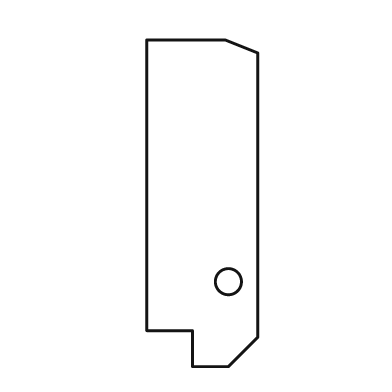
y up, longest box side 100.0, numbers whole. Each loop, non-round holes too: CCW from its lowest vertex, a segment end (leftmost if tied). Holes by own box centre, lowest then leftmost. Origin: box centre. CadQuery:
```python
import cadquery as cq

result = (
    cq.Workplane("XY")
    .moveTo(-3.0, -50.0)
    .lineTo(8.0, -50.0)
    .lineTo(17.0, -41.0)
    .lineTo(17.0, 46.0)
    .lineTo(7.0, 50.0)
    .lineTo(-17.0, 50.0)
    .lineTo(-17.0, -39.0)
    .lineTo(-3.0, -39.0)
    .close()
    .moveTo(8.0, -24.0)
    .circle(4.0)
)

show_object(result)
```